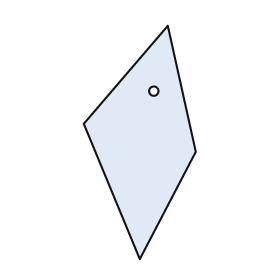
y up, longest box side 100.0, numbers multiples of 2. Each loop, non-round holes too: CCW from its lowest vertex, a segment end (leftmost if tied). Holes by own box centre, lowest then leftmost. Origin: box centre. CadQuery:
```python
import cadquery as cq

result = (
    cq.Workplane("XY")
    .moveTo(0.0, -50.0)
    .lineTo(24.0, -4.0)
    .lineTo(12.0, 50.0)
    .lineTo(-24.0, 8.0)
    .close()
    .moveTo(6.0, 22.0)
    .circle(2.0)
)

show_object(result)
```